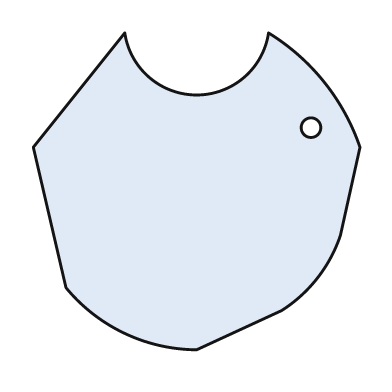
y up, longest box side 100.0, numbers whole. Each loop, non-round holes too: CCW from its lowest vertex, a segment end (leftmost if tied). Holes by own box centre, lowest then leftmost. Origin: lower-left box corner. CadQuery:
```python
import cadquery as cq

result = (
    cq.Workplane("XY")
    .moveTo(50.0, 0.0)
    .lineTo(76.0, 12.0)
    .threePointArc((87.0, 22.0), (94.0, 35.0))
    .lineTo(100.0, 62.0)
    .threePointArc((89.0, 82.0), (72.0, 97.0))
    .threePointArc((50.0, 78.0), (28.0, 97.0))
    .lineTo(0.0, 62.0)
    .lineTo(10.0, 19.0)
    .threePointArc((28.0, 5.0), (50.0, 0.0))
    .close()
    .moveTo(85.0, 68.0)
    .circle(3.0)
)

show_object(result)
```